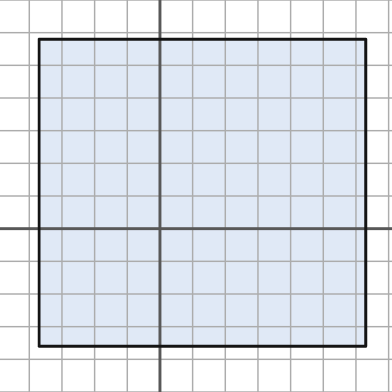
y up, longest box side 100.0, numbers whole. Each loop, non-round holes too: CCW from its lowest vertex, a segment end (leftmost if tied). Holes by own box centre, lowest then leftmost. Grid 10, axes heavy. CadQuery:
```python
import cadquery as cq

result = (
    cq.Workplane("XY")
    .moveTo(-37.0, -36.0)
    .lineTo(63.0, -36.0)
    .lineTo(63.0, 58.0)
    .lineTo(-37.0, 58.0)
    .close()
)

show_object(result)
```